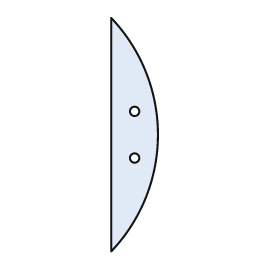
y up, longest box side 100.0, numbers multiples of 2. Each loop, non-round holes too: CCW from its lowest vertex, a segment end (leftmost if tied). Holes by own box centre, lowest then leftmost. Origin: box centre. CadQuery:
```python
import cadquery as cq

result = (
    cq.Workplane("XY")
    .moveTo(-10.0, -50.0)
    .threePointArc((10.0, 0.0), (-10.0, 50.0))
    .close()
    .moveTo(0.0, -10.0)
    .circle(2.0)
    .moveTo(0.0, 10.0)
    .circle(2.0)
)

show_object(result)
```